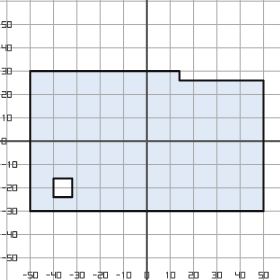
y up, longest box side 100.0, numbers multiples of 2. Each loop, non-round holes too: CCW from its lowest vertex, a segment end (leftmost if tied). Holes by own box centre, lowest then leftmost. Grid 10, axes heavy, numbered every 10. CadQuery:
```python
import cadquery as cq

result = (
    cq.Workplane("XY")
    .moveTo(-50.0, -30.0)
    .lineTo(50.0, -30.0)
    .lineTo(50.0, 26.0)
    .lineTo(14.0, 26.0)
    .lineTo(14.0, 30.0)
    .lineTo(-50.0, 30.0)
    .close()
    .moveTo(-40.0, -24.0)
    .lineTo(-32.0, -24.0)
    .lineTo(-32.0, -16.0)
    .lineTo(-40.0, -16.0)
    .close()
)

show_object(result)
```